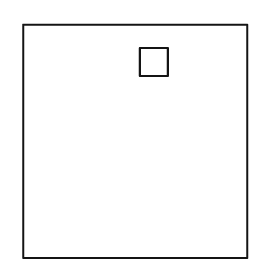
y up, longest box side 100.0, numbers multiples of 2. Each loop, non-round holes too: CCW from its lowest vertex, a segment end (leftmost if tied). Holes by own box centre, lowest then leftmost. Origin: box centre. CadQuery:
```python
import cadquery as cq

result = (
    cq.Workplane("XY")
    .moveTo(-48.0, -50.0)
    .lineTo(48.0, -50.0)
    .lineTo(48.0, 50.0)
    .lineTo(-48.0, 50.0)
    .close()
    .moveTo(2.0, 28.0)
    .lineTo(14.0, 28.0)
    .lineTo(14.0, 40.0)
    .lineTo(2.0, 40.0)
    .close()
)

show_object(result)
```